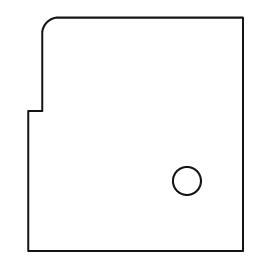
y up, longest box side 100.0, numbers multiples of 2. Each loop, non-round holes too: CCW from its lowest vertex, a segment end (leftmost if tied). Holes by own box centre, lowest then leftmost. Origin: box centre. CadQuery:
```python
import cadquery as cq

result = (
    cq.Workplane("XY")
    .moveTo(-46.0, -50.0)
    .lineTo(46.0, -50.0)
    .lineTo(46.0, 50.0)
    .lineTo(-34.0, 50.0)
    .threePointArc((-38.0, 48.0), (-40.0, 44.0))
    .lineTo(-40.0, 10.0)
    .lineTo(-46.0, 10.0)
    .close()
    .moveTo(22.0, -20.0)
    .circle(6.0)
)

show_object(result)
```